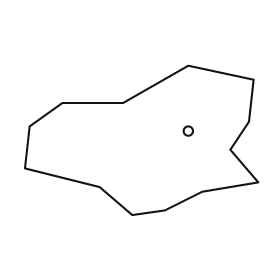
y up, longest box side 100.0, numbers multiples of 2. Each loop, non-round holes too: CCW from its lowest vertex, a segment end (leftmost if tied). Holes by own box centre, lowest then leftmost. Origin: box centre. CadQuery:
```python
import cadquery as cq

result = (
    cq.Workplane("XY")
    .moveTo(-4.0, -32.0)
    .lineTo(10.0, -30.0)
    .lineTo(26.0, -22.0)
    .lineTo(50.0, -18.0)
    .lineTo(38.0, -4.0)
    .lineTo(46.0, 8.0)
    .lineTo(48.0, 26.0)
    .lineTo(20.0, 32.0)
    .lineTo(-8.0, 16.0)
    .lineTo(-34.0, 16.0)
    .lineTo(-48.0, 6.0)
    .lineTo(-50.0, -12.0)
    .lineTo(-18.0, -20.0)
    .close()
    .moveTo(20.0, 4.0)
    .circle(2.0)
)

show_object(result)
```